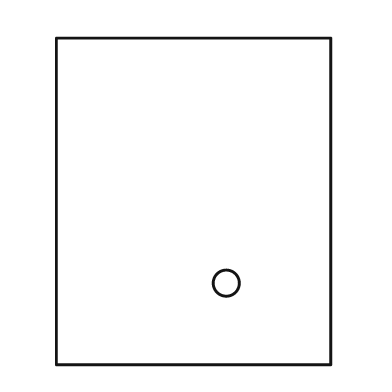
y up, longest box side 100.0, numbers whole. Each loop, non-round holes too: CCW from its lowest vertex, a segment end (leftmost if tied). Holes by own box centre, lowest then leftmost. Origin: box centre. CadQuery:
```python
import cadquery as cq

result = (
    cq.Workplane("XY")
    .moveTo(-42.0, -50.0)
    .lineTo(42.0, -50.0)
    .lineTo(42.0, 50.0)
    .lineTo(-42.0, 50.0)
    .close()
    .moveTo(10.0, -25.0)
    .circle(4.0)
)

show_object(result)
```